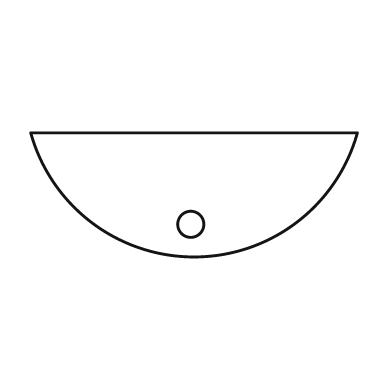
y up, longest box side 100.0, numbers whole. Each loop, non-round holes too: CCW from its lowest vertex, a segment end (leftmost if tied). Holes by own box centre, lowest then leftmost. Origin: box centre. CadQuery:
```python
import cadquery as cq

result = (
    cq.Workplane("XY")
    .moveTo(-50.0, 19.0)
    .threePointArc((0.0, -19.0), (50.0, 19.0))
    .close()
    .moveTo(-1.0, -9.0)
    .circle(4.0)
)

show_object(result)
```